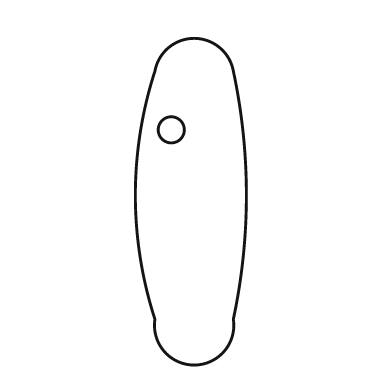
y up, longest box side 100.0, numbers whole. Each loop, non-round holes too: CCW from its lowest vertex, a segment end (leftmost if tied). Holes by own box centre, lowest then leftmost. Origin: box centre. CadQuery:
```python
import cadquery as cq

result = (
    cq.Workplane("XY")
    .moveTo(-11.0, -36.0)
    .threePointArc((1.0, -50.0), (13.0, -36.0))
    .threePointArc((17.0, 2.0), (13.0, 40.0))
    .threePointArc((1.0, 50.0), (-11.0, 40.0))
    .threePointArc((-17.0, 2.0), (-11.0, -36.0))
    .close()
    .moveTo(-6.0, 22.0)
    .circle(4.0)
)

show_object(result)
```